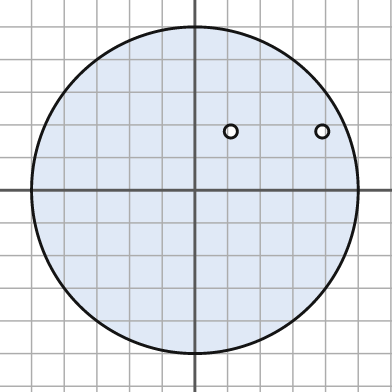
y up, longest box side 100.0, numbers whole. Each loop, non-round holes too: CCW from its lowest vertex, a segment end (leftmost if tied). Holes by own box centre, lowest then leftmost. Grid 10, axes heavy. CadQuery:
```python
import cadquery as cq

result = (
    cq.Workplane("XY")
    .moveTo(0.0, 0.0)
    .circle(50.0)
    .moveTo(11.0, 18.0)
    .circle(2.0)
    .moveTo(39.0, 18.0)
    .circle(2.0)
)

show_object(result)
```